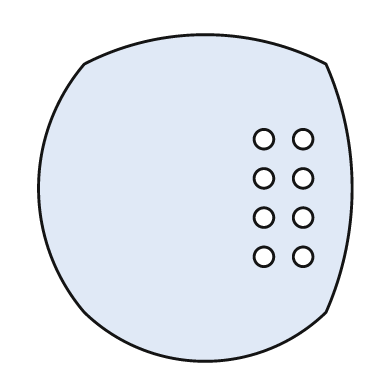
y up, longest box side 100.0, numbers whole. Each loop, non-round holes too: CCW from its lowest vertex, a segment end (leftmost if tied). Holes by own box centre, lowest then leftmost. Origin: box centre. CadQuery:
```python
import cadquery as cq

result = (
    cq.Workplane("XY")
    .moveTo(-34.0, -35.0)
    .threePointArc((3.0, -50.0), (40.0, -35.0))
    .threePointArc((48.0, 3.0), (40.0, 41.0))
    .threePointArc((3.0, 50.0), (-34.0, 41.0))
    .threePointArc((-48.0, 3.0), (-34.0, -35.0))
    .close()
    .moveTo(21.0, -18.0)
    .circle(3.0)
    .moveTo(33.0, -18.0)
    .circle(3.0)
    .moveTo(21.0, -6.0)
    .circle(3.0)
    .moveTo(33.0, -6.0)
    .circle(3.0)
    .moveTo(21.0, 6.0)
    .circle(3.0)
    .moveTo(33.0, 6.0)
    .circle(3.0)
    .moveTo(21.0, 18.0)
    .circle(3.0)
    .moveTo(33.0, 18.0)
    .circle(3.0)
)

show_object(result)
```